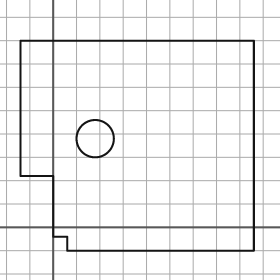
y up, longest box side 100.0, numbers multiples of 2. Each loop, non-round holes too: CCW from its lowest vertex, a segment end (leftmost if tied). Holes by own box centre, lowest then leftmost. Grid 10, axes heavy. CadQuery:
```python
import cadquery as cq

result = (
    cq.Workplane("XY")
    .moveTo(6.0, -10.0)
    .lineTo(86.0, -10.0)
    .lineTo(86.0, 80.0)
    .lineTo(-14.0, 80.0)
    .lineTo(-14.0, 22.0)
    .lineTo(0.0, 22.0)
    .lineTo(0.0, -4.0)
    .lineTo(6.0, -4.0)
    .close()
    .moveTo(18.0, 38.0)
    .circle(8.0)
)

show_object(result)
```